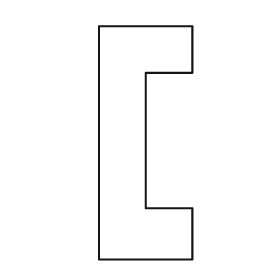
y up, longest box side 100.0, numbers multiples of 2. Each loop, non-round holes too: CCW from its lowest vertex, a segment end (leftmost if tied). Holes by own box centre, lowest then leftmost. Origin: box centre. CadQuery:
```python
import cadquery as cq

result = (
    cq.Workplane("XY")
    .moveTo(-20.0, -50.0)
    .lineTo(20.0, -50.0)
    .lineTo(20.0, -28.0)
    .lineTo(0.0, -28.0)
    .lineTo(0.0, 30.0)
    .lineTo(20.0, 30.0)
    .lineTo(20.0, 50.0)
    .lineTo(-20.0, 50.0)
    .close()
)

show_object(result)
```